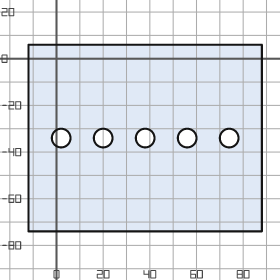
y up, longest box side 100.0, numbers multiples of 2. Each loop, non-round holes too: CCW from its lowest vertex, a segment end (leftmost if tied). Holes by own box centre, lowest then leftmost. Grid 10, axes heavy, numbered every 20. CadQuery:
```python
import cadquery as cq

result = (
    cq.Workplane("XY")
    .moveTo(-12.0, -74.0)
    .lineTo(88.0, -74.0)
    .lineTo(88.0, 6.0)
    .lineTo(-12.0, 6.0)
    .close()
    .moveTo(2.0, -34.0)
    .circle(4.0)
    .moveTo(20.0, -34.0)
    .circle(4.0)
    .moveTo(38.0, -34.0)
    .circle(4.0)
    .moveTo(56.0, -34.0)
    .circle(4.0)
    .moveTo(74.0, -34.0)
    .circle(4.0)
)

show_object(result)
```